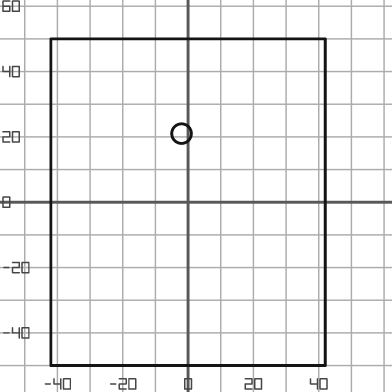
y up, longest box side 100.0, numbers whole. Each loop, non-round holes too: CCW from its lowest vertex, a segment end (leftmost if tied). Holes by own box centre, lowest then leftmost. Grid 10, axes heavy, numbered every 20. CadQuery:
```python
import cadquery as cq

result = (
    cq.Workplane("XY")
    .moveTo(-42.0, -50.0)
    .lineTo(42.0, -50.0)
    .lineTo(42.0, 50.0)
    .lineTo(-42.0, 50.0)
    .close()
    .moveTo(-2.0, 21.0)
    .circle(3.0)
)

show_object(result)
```